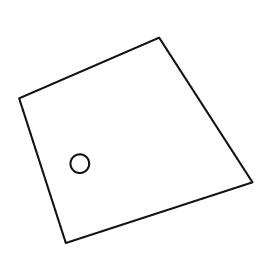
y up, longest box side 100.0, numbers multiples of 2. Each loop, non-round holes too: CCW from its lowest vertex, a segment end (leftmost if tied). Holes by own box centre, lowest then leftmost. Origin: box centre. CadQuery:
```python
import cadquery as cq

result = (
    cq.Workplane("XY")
    .moveTo(-30.0, -44.0)
    .lineTo(50.0, -18.0)
    .lineTo(10.0, 44.0)
    .lineTo(-50.0, 18.0)
    .close()
    .moveTo(-24.0, -10.0)
    .circle(4.0)
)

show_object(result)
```